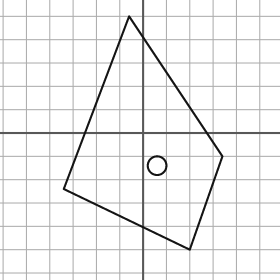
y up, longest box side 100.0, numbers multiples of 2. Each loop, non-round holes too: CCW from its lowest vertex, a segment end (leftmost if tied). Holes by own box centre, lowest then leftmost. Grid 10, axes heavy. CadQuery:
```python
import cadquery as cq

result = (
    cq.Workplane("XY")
    .moveTo(20.0, -50.0)
    .lineTo(34.0, -10.0)
    .lineTo(-6.0, 50.0)
    .lineTo(-34.0, -24.0)
    .close()
    .moveTo(6.0, -14.0)
    .circle(4.0)
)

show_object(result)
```